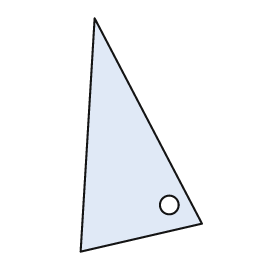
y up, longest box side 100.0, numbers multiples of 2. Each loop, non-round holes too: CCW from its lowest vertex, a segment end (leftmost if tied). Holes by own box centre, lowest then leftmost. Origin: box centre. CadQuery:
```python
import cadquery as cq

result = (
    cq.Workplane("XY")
    .moveTo(-26.0, -50.0)
    .lineTo(26.0, -38.0)
    .lineTo(-20.0, 50.0)
    .close()
    .moveTo(12.0, -30.0)
    .circle(4.0)
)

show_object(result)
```